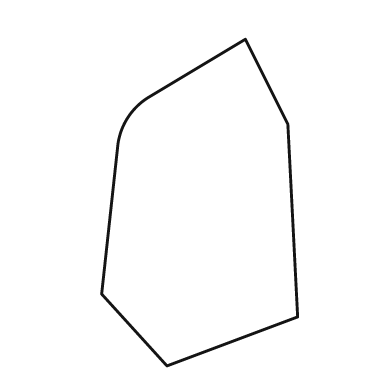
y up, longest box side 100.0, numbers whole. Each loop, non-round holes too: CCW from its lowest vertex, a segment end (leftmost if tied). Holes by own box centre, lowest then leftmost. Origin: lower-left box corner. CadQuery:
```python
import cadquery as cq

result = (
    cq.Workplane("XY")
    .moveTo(20.0, 0.0)
    .lineTo(60.0, 15.0)
    .lineTo(57.0, 74.0)
    .lineTo(44.0, 100.0)
    .lineTo(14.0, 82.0)
    .threePointArc((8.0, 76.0), (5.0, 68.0))
    .lineTo(0.0, 22.0)
    .close()
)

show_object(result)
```